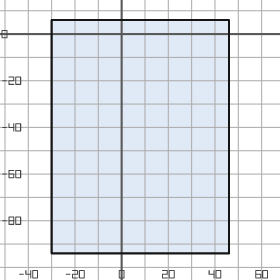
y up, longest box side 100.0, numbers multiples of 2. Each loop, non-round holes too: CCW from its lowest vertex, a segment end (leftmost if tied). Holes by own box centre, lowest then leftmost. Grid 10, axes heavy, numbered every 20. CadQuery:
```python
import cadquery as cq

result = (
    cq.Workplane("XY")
    .moveTo(-30.0, -94.0)
    .lineTo(46.0, -94.0)
    .lineTo(46.0, 6.0)
    .lineTo(-30.0, 6.0)
    .close()
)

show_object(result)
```